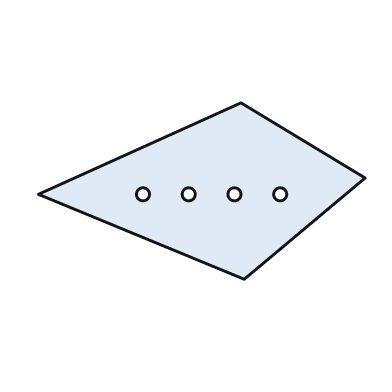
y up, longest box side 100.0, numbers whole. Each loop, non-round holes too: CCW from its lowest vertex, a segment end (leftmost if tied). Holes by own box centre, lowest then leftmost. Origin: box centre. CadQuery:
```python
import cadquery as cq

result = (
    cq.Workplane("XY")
    .moveTo(13.0, -27.0)
    .lineTo(50.0, 4.0)
    .lineTo(12.0, 27.0)
    .lineTo(-50.0, -1.0)
    .close()
    .moveTo(-18.0, -1.0)
    .circle(2.0)
    .moveTo(-4.0, -1.0)
    .circle(2.0)
    .moveTo(10.0, -1.0)
    .circle(2.0)
    .moveTo(24.0, -1.0)
    .circle(2.0)
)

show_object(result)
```